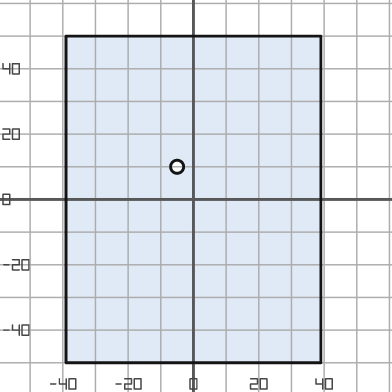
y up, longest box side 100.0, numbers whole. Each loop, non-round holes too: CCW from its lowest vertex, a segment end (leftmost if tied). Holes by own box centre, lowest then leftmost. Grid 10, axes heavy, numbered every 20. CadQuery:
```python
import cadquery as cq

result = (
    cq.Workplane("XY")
    .moveTo(-39.0, -50.0)
    .lineTo(39.0, -50.0)
    .lineTo(39.0, 50.0)
    .lineTo(-39.0, 50.0)
    .close()
    .moveTo(-5.0, 10.0)
    .circle(2.0)
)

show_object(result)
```